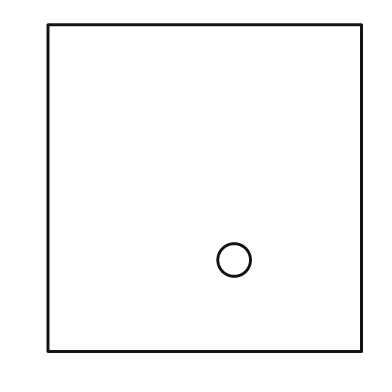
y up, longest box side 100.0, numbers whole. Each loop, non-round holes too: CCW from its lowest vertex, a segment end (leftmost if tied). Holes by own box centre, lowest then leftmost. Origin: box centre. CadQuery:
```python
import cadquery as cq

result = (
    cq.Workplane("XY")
    .moveTo(-48.0, -50.0)
    .lineTo(48.0, -50.0)
    .lineTo(48.0, 50.0)
    .lineTo(-48.0, 50.0)
    .close()
    .moveTo(9.0, -22.0)
    .circle(5.0)
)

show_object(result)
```